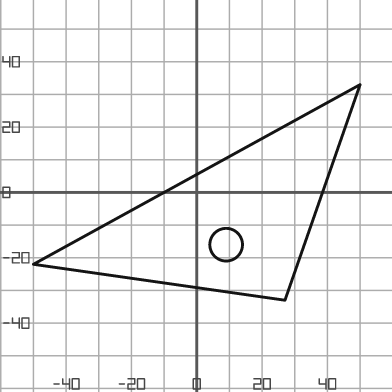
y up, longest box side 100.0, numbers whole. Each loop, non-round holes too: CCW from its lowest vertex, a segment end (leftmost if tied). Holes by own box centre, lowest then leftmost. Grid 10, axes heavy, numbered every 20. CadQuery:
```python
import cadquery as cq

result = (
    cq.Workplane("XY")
    .moveTo(27.0, -33.0)
    .lineTo(50.0, 33.0)
    .lineTo(-50.0, -22.0)
    .close()
    .moveTo(9.0, -16.0)
    .circle(5.0)
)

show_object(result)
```